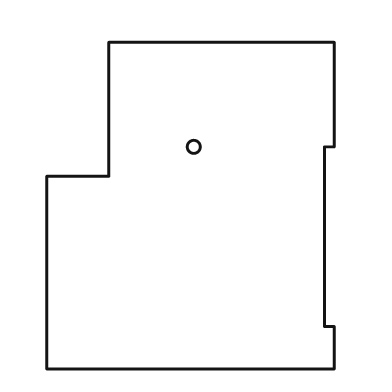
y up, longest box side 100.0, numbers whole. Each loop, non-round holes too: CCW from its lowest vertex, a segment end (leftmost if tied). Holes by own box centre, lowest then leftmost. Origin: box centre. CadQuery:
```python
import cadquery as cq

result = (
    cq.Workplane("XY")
    .moveTo(-44.0, -50.0)
    .lineTo(44.0, -50.0)
    .lineTo(44.0, -37.0)
    .lineTo(41.0, -37.0)
    .lineTo(41.0, 18.0)
    .lineTo(44.0, 18.0)
    .lineTo(44.0, 50.0)
    .lineTo(-25.0, 50.0)
    .lineTo(-25.0, 9.0)
    .lineTo(-44.0, 9.0)
    .close()
    .moveTo(1.0, 18.0)
    .circle(2.0)
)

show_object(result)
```